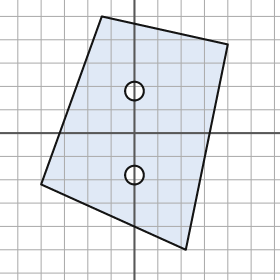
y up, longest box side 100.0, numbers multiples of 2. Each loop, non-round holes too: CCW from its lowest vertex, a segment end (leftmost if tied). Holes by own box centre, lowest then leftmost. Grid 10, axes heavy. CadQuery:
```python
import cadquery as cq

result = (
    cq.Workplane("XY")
    .moveTo(22.0, -50.0)
    .lineTo(40.0, 38.0)
    .lineTo(-14.0, 50.0)
    .lineTo(-40.0, -22.0)
    .close()
    .moveTo(0.0, -18.0)
    .circle(4.0)
    .moveTo(0.0, 18.0)
    .circle(4.0)
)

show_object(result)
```